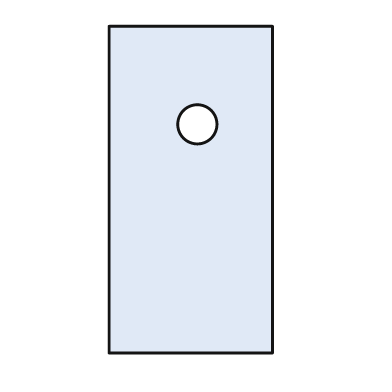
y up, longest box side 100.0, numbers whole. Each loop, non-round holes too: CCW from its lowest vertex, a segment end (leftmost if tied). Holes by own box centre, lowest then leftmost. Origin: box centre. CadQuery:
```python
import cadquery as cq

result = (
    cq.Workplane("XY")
    .moveTo(-25.0, -50.0)
    .lineTo(25.0, -50.0)
    .lineTo(25.0, 50.0)
    .lineTo(-25.0, 50.0)
    .close()
    .moveTo(2.0, 20.0)
    .circle(6.0)
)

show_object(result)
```